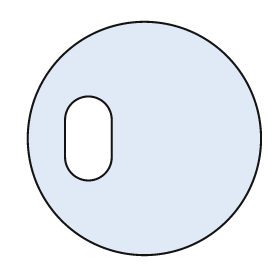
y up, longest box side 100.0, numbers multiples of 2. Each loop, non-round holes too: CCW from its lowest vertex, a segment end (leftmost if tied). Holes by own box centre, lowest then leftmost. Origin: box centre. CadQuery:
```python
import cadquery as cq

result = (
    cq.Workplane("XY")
    .moveTo(0.0, 0.0)
    .circle(50.0)
    .moveTo(-34.0, -8.0)
    .threePointArc((-24.0, -18.0), (-14.0, -8.0))
    .lineTo(-14.0, 8.0)
    .threePointArc((-24.0, 18.0), (-34.0, 8.0))
    .close()
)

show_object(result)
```